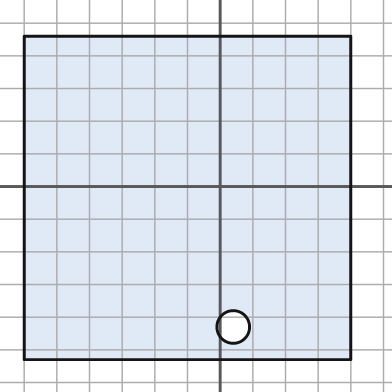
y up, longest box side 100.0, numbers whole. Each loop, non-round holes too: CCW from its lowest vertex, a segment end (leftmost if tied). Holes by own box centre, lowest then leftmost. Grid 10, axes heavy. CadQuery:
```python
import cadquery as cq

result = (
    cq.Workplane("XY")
    .moveTo(-60.0, -53.0)
    .lineTo(40.0, -53.0)
    .lineTo(40.0, 46.0)
    .lineTo(-60.0, 46.0)
    .close()
    .moveTo(4.0, -43.0)
    .circle(5.0)
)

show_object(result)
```